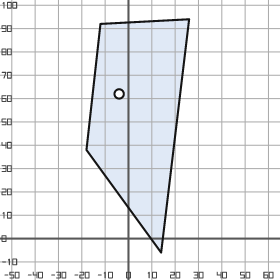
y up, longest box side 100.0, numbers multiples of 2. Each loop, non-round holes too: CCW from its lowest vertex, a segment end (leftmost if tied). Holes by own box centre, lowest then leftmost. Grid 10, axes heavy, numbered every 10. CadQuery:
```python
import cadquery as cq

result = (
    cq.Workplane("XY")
    .moveTo(14.0, -6.0)
    .lineTo(26.0, 94.0)
    .lineTo(-12.0, 92.0)
    .lineTo(-18.0, 38.0)
    .close()
    .moveTo(-4.0, 62.0)
    .circle(2.0)
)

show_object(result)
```